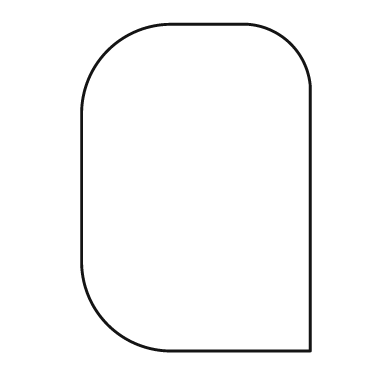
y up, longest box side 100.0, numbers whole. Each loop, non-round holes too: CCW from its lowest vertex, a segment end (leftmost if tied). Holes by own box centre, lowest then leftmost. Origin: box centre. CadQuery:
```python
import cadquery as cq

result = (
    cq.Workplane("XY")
    .moveTo(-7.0, -50.0)
    .lineTo(35.0, -50.0)
    .lineTo(35.0, 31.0)
    .threePointArc((29.0, 44.0), (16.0, 50.0))
    .lineTo(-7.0, 50.0)
    .threePointArc((-27.0, 42.0), (-35.0, 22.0))
    .lineTo(-35.0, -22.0)
    .threePointArc((-27.0, -42.0), (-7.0, -50.0))
    .close()
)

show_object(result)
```